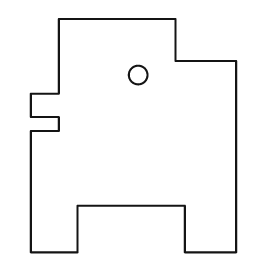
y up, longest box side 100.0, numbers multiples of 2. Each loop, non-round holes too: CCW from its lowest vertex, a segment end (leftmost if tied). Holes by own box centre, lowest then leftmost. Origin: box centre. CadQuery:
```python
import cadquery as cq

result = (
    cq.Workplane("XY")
    .moveTo(-44.0, -50.0)
    .lineTo(-24.0, -50.0)
    .lineTo(-24.0, -30.0)
    .lineTo(22.0, -30.0)
    .lineTo(22.0, -50.0)
    .lineTo(44.0, -50.0)
    .lineTo(44.0, 32.0)
    .lineTo(18.0, 32.0)
    .lineTo(18.0, 50.0)
    .lineTo(-32.0, 50.0)
    .lineTo(-32.0, 18.0)
    .lineTo(-44.0, 18.0)
    .lineTo(-44.0, 8.0)
    .lineTo(-32.0, 8.0)
    .lineTo(-32.0, 2.0)
    .lineTo(-44.0, 2.0)
    .close()
    .moveTo(2.0, 26.0)
    .circle(4.0)
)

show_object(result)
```